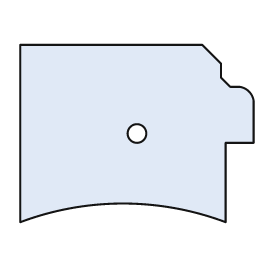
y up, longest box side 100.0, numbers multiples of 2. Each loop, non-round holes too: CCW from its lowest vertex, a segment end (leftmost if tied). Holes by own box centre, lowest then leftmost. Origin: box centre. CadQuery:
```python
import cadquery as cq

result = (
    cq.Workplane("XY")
    .moveTo(-50.0, -38.0)
    .threePointArc((-6.0, -30.0), (38.0, -38.0))
    .lineTo(38.0, -4.0)
    .lineTo(50.0, -4.0)
    .lineTo(50.0, 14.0)
    .threePointArc((48.0, 18.0), (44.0, 20.0))
    .lineTo(40.0, 20.0)
    .lineTo(36.0, 24.0)
    .lineTo(36.0, 30.0)
    .lineTo(28.0, 38.0)
    .lineTo(-50.0, 38.0)
    .close()
    .moveTo(0.0, 0.0)
    .circle(4.0)
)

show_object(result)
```